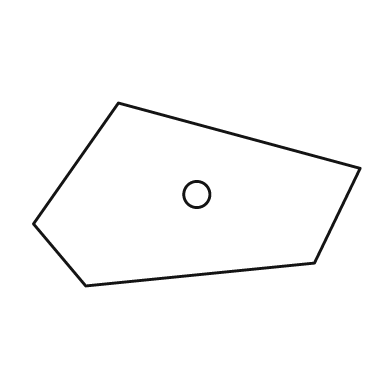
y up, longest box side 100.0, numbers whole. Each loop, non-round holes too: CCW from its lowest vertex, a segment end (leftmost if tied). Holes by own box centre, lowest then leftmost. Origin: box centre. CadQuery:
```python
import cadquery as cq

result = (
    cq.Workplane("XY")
    .moveTo(-34.0, -28.0)
    .lineTo(36.0, -21.0)
    .lineTo(50.0, 8.0)
    .lineTo(-24.0, 28.0)
    .lineTo(-50.0, -9.0)
    .close()
    .moveTo(0.0, 0.0)
    .circle(4.0)
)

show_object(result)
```